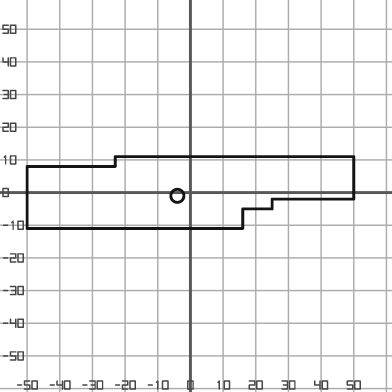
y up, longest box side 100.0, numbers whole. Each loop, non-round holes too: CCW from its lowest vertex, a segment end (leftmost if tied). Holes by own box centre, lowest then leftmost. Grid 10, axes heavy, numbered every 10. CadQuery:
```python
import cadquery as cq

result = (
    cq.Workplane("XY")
    .moveTo(-50.0, -11.0)
    .lineTo(16.0, -11.0)
    .lineTo(16.0, -5.0)
    .lineTo(25.0, -5.0)
    .lineTo(25.0, -2.0)
    .lineTo(50.0, -2.0)
    .lineTo(50.0, 11.0)
    .lineTo(-23.0, 11.0)
    .lineTo(-23.0, 8.0)
    .lineTo(-50.0, 8.0)
    .close()
    .moveTo(-4.0, -1.0)
    .circle(2.0)
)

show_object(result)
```